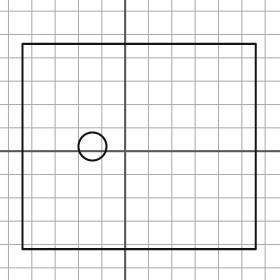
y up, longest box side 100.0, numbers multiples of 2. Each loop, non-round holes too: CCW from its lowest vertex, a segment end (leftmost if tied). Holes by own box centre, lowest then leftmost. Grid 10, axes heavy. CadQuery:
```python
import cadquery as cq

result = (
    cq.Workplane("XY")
    .moveTo(-44.0, -42.0)
    .lineTo(56.0, -42.0)
    .lineTo(56.0, 46.0)
    .lineTo(-44.0, 46.0)
    .close()
    .moveTo(-14.0, 2.0)
    .circle(6.0)
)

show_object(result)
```